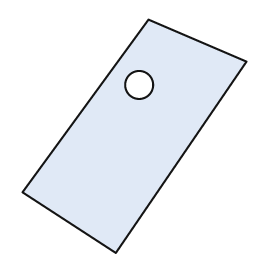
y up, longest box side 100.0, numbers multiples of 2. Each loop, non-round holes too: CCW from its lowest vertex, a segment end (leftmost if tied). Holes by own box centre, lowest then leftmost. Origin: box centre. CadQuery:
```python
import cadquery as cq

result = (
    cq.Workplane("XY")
    .moveTo(-8.0, -50.0)
    .lineTo(48.0, 32.0)
    .lineTo(6.0, 50.0)
    .lineTo(-48.0, -24.0)
    .close()
    .moveTo(2.0, 22.0)
    .circle(6.0)
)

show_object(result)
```